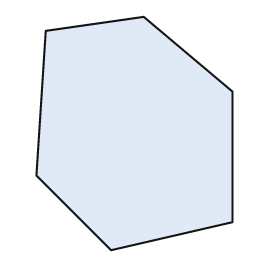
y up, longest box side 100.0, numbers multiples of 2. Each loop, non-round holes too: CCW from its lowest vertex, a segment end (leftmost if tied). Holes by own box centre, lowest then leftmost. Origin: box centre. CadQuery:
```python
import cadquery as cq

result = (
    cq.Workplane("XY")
    .moveTo(-10.0, -50.0)
    .lineTo(42.0, -38.0)
    .lineTo(42.0, 18.0)
    .lineTo(4.0, 50.0)
    .lineTo(-38.0, 44.0)
    .lineTo(-42.0, -18.0)
    .close()
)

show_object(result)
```